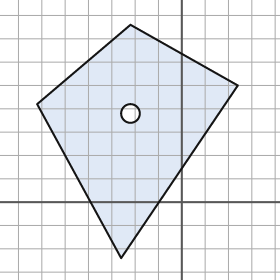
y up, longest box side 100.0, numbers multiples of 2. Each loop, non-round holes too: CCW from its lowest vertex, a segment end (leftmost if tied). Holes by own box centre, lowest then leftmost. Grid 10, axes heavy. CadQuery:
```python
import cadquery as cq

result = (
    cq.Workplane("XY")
    .moveTo(-26.0, -24.0)
    .lineTo(24.0, 50.0)
    .lineTo(-22.0, 76.0)
    .lineTo(-62.0, 42.0)
    .close()
    .moveTo(-22.0, 38.0)
    .circle(4.0)
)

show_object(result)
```